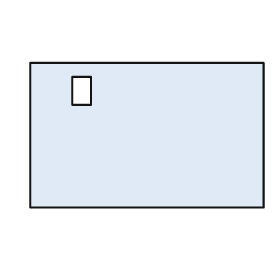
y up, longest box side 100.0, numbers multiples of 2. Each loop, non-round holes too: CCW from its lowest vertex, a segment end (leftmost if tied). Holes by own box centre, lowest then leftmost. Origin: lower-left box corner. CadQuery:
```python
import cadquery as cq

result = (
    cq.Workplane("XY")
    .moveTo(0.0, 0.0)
    .lineTo(100.0, 0.0)
    .lineTo(100.0, 62.0)
    .lineTo(0.0, 62.0)
    .close()
    .moveTo(18.0, 44.0)
    .lineTo(26.0, 44.0)
    .lineTo(26.0, 56.0)
    .lineTo(18.0, 56.0)
    .close()
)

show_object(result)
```